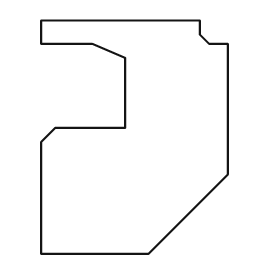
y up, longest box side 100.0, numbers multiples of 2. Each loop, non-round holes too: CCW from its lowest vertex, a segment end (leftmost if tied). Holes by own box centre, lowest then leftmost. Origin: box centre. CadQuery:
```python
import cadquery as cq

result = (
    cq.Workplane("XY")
    .moveTo(-40.0, -50.0)
    .lineTo(6.0, -50.0)
    .lineTo(40.0, -16.0)
    .lineTo(40.0, 40.0)
    .lineTo(32.0, 40.0)
    .lineTo(28.0, 44.0)
    .lineTo(28.0, 50.0)
    .lineTo(-40.0, 50.0)
    .lineTo(-40.0, 40.0)
    .lineTo(-18.0, 40.0)
    .lineTo(-4.0, 34.0)
    .lineTo(-4.0, 4.0)
    .lineTo(-34.0, 4.0)
    .lineTo(-40.0, -2.0)
    .close()
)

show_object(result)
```